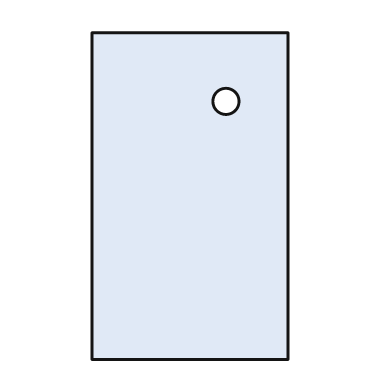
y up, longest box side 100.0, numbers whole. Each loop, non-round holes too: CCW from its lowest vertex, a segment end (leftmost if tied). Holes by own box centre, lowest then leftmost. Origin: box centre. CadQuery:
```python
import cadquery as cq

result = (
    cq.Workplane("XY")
    .moveTo(-30.0, -50.0)
    .lineTo(30.0, -50.0)
    .lineTo(30.0, 50.0)
    .lineTo(-30.0, 50.0)
    .close()
    .moveTo(11.0, 29.0)
    .circle(4.0)
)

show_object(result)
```